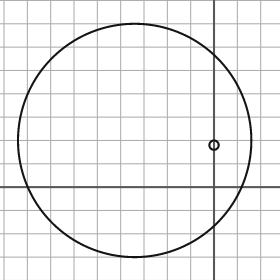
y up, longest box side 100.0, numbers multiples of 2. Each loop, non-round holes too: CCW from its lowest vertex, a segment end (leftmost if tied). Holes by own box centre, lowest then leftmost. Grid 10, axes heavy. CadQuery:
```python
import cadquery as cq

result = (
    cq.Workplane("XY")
    .moveTo(-34.0, 20.0)
    .circle(50.0)
    .moveTo(0.0, 18.0)
    .circle(2.0)
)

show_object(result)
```